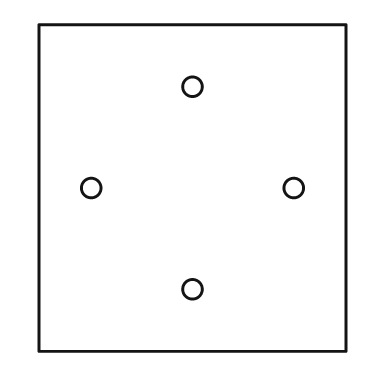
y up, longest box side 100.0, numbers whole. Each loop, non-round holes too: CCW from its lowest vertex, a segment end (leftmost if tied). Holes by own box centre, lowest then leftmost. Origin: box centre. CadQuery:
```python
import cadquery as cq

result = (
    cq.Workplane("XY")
    .moveTo(-47.0, -50.0)
    .lineTo(47.0, -50.0)
    .lineTo(47.0, 50.0)
    .lineTo(-47.0, 50.0)
    .close()
    .moveTo(0.0, -31.0)
    .circle(3.0)
    .moveTo(-31.0, 0.0)
    .circle(3.0)
    .moveTo(31.0, 0.0)
    .circle(3.0)
    .moveTo(0.0, 31.0)
    .circle(3.0)
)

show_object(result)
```